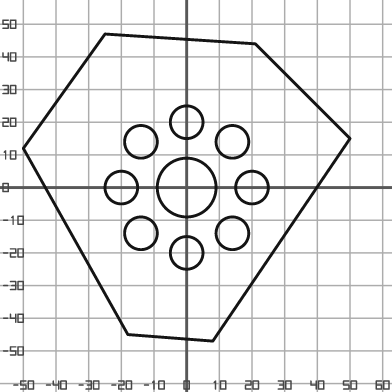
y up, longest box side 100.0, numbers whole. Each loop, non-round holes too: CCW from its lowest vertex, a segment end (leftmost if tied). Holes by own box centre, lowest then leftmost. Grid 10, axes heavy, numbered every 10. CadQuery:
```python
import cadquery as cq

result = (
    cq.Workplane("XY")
    .moveTo(8.0, -47.0)
    .lineTo(50.0, 15.0)
    .lineTo(21.0, 44.0)
    .lineTo(-25.0, 47.0)
    .lineTo(-50.0, 12.0)
    .lineTo(-18.0, -45.0)
    .close()
    .moveTo(0.0, -20.0)
    .circle(5.0)
    .moveTo(-14.0, -14.0)
    .circle(5.0)
    .moveTo(14.0, -14.0)
    .circle(5.0)
    .moveTo(-20.0, 0.0)
    .circle(5.0)
    .moveTo(0.0, 0.0)
    .circle(9.0)
    .moveTo(20.0, 0.0)
    .circle(5.0)
    .moveTo(-14.0, 14.0)
    .circle(5.0)
    .moveTo(14.0, 14.0)
    .circle(5.0)
    .moveTo(0.0, 20.0)
    .circle(5.0)
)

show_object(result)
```